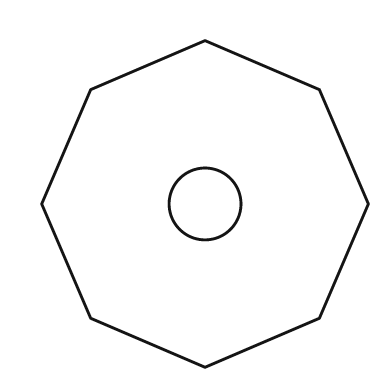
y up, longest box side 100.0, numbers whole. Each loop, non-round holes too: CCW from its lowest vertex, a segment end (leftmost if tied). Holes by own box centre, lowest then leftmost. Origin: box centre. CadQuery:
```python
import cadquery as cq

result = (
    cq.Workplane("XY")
    .moveTo(0.0, -50.0)
    .lineTo(35.0, -35.0)
    .lineTo(50.0, 0.0)
    .lineTo(35.0, 35.0)
    .lineTo(0.0, 50.0)
    .lineTo(-35.0, 35.0)
    .lineTo(-50.0, 0.0)
    .lineTo(-35.0, -35.0)
    .close()
    .moveTo(0.0, 0.0)
    .circle(11.0)
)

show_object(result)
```